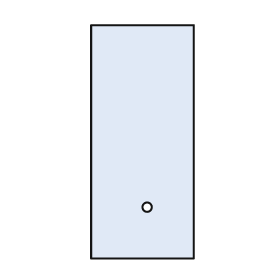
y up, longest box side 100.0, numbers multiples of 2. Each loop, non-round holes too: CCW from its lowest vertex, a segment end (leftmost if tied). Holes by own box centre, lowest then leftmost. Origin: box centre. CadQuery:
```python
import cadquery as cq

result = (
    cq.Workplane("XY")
    .moveTo(-22.0, -50.0)
    .lineTo(22.0, -50.0)
    .lineTo(22.0, 50.0)
    .lineTo(-22.0, 50.0)
    .close()
    .moveTo(2.0, -28.0)
    .circle(2.0)
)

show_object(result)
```